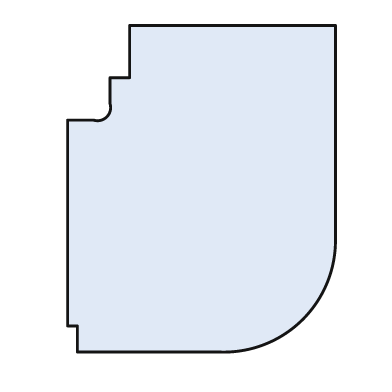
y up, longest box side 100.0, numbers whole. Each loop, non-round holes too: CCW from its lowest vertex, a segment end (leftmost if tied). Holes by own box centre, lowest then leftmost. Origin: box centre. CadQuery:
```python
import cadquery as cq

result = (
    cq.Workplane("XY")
    .moveTo(-38.0, -50.0)
    .lineTo(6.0, -50.0)
    .threePointArc((31.0, -40.0), (41.0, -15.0))
    .lineTo(41.0, 50.0)
    .lineTo(-22.0, 50.0)
    .lineTo(-22.0, 34.0)
    .lineTo(-28.0, 34.0)
    .lineTo(-28.0, 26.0)
    .threePointArc((-29.0, 22.0), (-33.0, 21.0))
    .lineTo(-41.0, 21.0)
    .lineTo(-41.0, -42.0)
    .lineTo(-38.0, -42.0)
    .close()
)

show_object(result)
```